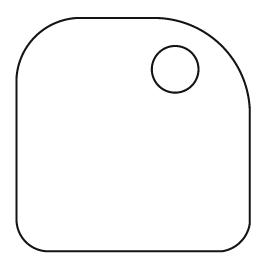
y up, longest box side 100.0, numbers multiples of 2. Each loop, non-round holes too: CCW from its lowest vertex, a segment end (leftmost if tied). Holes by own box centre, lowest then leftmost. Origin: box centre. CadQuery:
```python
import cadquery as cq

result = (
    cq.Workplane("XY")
    .moveTo(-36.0, -50.0)
    .lineTo(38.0, -50.0)
    .threePointArc((46.0, -46.0), (50.0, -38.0))
    .lineTo(50.0, 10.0)
    .threePointArc((38.0, 38.0), (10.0, 50.0))
    .lineTo(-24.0, 50.0)
    .threePointArc((-42.0, 42.0), (-50.0, 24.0))
    .lineTo(-50.0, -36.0)
    .threePointArc((-46.0, -46.0), (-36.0, -50.0))
    .close()
    .moveTo(18.0, 28.0)
    .circle(10.0)
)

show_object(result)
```